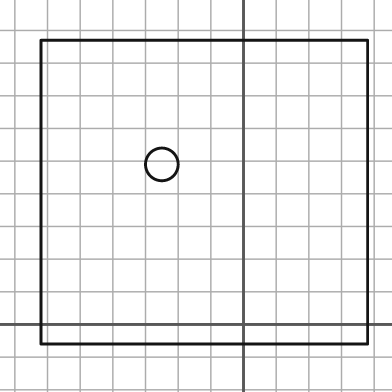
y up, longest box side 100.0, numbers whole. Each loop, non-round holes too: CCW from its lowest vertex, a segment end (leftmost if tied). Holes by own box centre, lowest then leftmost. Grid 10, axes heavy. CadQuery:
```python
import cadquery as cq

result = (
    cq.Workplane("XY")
    .moveTo(-62.0, -6.0)
    .lineTo(38.0, -6.0)
    .lineTo(38.0, 87.0)
    .lineTo(-62.0, 87.0)
    .close()
    .moveTo(-25.0, 49.0)
    .circle(5.0)
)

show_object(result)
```